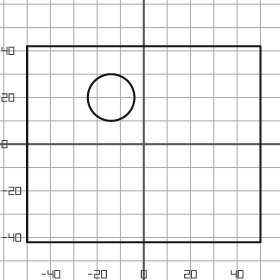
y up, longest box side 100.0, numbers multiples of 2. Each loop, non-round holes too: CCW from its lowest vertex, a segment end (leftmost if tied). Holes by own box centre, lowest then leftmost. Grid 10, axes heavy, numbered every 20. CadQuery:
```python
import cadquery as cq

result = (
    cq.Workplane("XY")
    .moveTo(-50.0, -42.0)
    .lineTo(50.0, -42.0)
    .lineTo(50.0, 42.0)
    .lineTo(-50.0, 42.0)
    .close()
    .moveTo(-14.0, 20.0)
    .circle(10.0)
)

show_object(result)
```